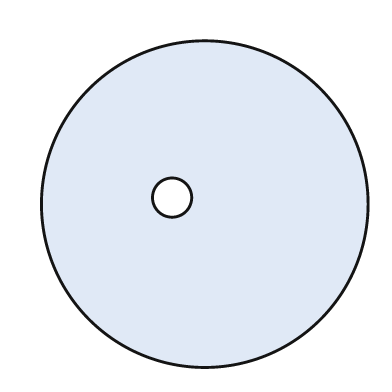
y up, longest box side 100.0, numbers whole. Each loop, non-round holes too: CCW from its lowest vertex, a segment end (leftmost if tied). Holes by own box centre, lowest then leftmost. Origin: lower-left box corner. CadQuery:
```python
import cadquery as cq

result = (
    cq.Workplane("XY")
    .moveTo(50.0, 50.0)
    .circle(50.0)
    .moveTo(40.0, 52.0)
    .circle(6.0)
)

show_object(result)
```